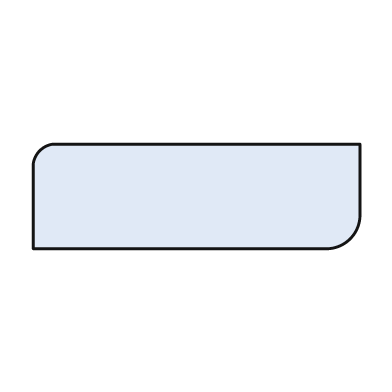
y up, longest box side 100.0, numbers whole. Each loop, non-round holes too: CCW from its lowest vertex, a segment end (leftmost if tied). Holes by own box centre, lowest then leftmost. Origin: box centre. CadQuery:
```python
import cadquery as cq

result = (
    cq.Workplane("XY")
    .moveTo(-50.0, -16.0)
    .lineTo(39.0, -16.0)
    .threePointArc((47.0, -13.0), (50.0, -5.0))
    .lineTo(50.0, 16.0)
    .lineTo(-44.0, 16.0)
    .threePointArc((-48.0, 14.0), (-50.0, 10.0))
    .close()
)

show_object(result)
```